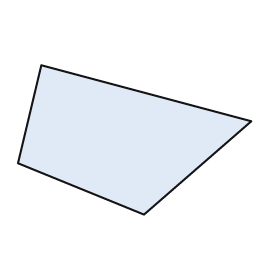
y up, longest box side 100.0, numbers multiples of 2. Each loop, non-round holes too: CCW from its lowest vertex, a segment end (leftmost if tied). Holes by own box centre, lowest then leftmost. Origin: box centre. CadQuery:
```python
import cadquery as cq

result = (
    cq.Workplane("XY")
    .moveTo(4.0, -32.0)
    .lineTo(50.0, 8.0)
    .lineTo(-40.0, 32.0)
    .lineTo(-50.0, -10.0)
    .close()
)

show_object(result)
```